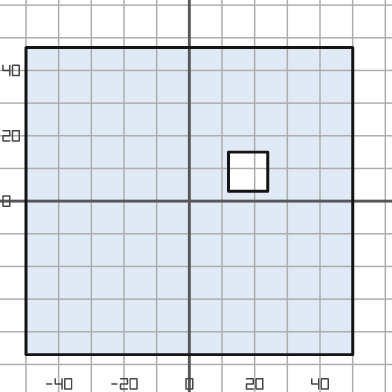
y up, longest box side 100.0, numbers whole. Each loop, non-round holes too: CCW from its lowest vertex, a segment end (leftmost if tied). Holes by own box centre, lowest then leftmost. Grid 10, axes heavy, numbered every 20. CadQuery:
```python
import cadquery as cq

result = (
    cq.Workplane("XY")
    .moveTo(-50.0, -47.0)
    .lineTo(50.0, -47.0)
    .lineTo(50.0, 47.0)
    .lineTo(-50.0, 47.0)
    .close()
    .moveTo(12.0, 3.0)
    .lineTo(24.0, 3.0)
    .lineTo(24.0, 15.0)
    .lineTo(12.0, 15.0)
    .close()
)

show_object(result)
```